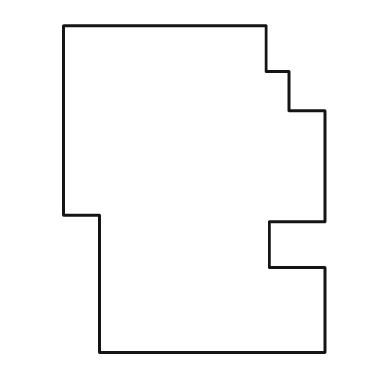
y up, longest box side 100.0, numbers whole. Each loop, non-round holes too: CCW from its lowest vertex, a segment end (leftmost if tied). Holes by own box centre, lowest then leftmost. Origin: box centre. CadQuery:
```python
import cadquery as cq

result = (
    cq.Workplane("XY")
    .moveTo(-29.0, -50.0)
    .lineTo(40.0, -50.0)
    .lineTo(40.0, -24.0)
    .lineTo(23.0, -24.0)
    .lineTo(23.0, -10.0)
    .lineTo(40.0, -10.0)
    .lineTo(40.0, 24.0)
    .lineTo(29.0, 24.0)
    .lineTo(29.0, 36.0)
    .lineTo(22.0, 36.0)
    .lineTo(22.0, 50.0)
    .lineTo(-40.0, 50.0)
    .lineTo(-40.0, -8.0)
    .lineTo(-29.0, -8.0)
    .close()
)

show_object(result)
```